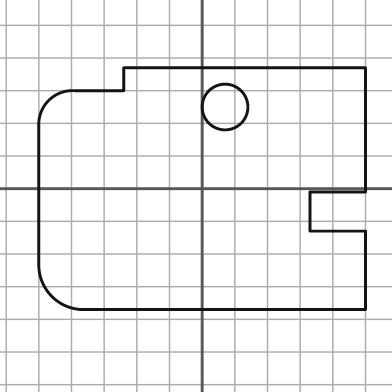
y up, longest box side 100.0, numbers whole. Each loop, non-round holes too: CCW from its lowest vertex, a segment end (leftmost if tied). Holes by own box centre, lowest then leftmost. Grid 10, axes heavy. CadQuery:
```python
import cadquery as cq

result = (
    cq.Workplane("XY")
    .moveTo(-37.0, -37.0)
    .lineTo(50.0, -37.0)
    .lineTo(50.0, -13.0)
    .lineTo(33.0, -13.0)
    .lineTo(33.0, -1.0)
    .lineTo(50.0, -1.0)
    .lineTo(50.0, 37.0)
    .lineTo(-24.0, 37.0)
    .lineTo(-24.0, 30.0)
    .lineTo(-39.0, 30.0)
    .threePointArc((-47.0, 27.0), (-50.0, 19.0))
    .lineTo(-50.0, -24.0)
    .threePointArc((-46.0, -33.0), (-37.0, -37.0))
    .close()
    .moveTo(7.0, 25.0)
    .circle(7.0)
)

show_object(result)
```